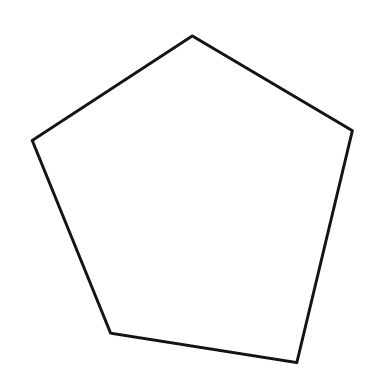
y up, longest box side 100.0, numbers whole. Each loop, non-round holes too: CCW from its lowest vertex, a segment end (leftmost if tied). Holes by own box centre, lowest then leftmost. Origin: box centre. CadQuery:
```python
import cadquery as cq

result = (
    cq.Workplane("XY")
    .moveTo(32.0, -50.0)
    .lineTo(49.0, 21.0)
    .lineTo(0.0, 50.0)
    .lineTo(-49.0, 18.0)
    .lineTo(-25.0, -41.0)
    .close()
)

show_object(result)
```